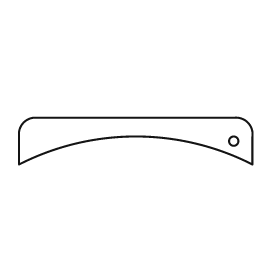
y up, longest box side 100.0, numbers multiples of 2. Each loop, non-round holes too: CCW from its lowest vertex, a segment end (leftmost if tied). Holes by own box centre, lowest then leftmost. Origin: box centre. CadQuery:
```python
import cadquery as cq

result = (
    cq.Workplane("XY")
    .moveTo(-50.0, -10.0)
    .threePointArc((0.0, 2.0), (50.0, -10.0))
    .lineTo(50.0, 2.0)
    .threePointArc((48.0, 8.0), (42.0, 10.0))
    .lineTo(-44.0, 10.0)
    .threePointArc((-48.0, 8.0), (-50.0, 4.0))
    .close()
    .moveTo(42.0, 0.0)
    .circle(2.0)
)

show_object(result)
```